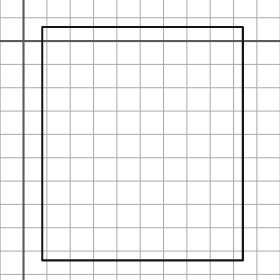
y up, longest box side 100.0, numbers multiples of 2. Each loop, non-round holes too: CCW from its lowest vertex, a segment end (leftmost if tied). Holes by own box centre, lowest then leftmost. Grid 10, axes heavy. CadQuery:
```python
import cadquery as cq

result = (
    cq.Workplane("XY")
    .moveTo(8.0, -94.0)
    .lineTo(94.0, -94.0)
    .lineTo(94.0, 6.0)
    .lineTo(8.0, 6.0)
    .close()
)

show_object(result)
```